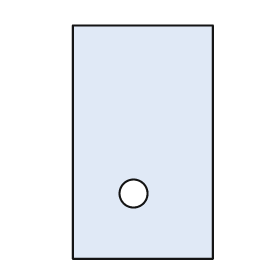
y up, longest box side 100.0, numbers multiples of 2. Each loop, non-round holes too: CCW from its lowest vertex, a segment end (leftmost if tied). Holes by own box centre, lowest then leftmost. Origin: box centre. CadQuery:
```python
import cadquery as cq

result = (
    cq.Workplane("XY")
    .moveTo(-30.0, -50.0)
    .lineTo(30.0, -50.0)
    .lineTo(30.0, 50.0)
    .lineTo(-30.0, 50.0)
    .close()
    .moveTo(-4.0, -22.0)
    .circle(6.0)
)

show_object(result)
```